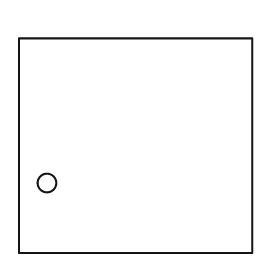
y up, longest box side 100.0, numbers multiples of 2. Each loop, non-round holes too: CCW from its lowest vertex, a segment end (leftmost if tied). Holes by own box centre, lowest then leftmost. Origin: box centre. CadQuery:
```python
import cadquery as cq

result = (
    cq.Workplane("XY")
    .moveTo(-50.0, -46.0)
    .lineTo(50.0, -46.0)
    .lineTo(50.0, 46.0)
    .lineTo(-50.0, 46.0)
    .close()
    .moveTo(-38.0, -16.0)
    .circle(4.0)
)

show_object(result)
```